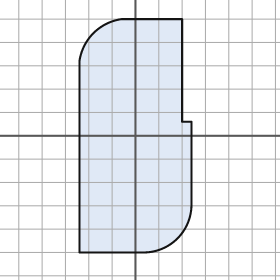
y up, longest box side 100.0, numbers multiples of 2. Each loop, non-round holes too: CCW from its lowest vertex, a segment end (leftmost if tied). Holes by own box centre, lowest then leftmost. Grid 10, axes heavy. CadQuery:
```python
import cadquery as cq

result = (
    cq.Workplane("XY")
    .moveTo(-24.0, -50.0)
    .lineTo(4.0, -50.0)
    .threePointArc((18.0, -44.0), (24.0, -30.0))
    .lineTo(24.0, 6.0)
    .lineTo(20.0, 6.0)
    .lineTo(20.0, 50.0)
    .lineTo(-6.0, 50.0)
    .threePointArc((-18.0, 44.0), (-24.0, 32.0))
    .close()
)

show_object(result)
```